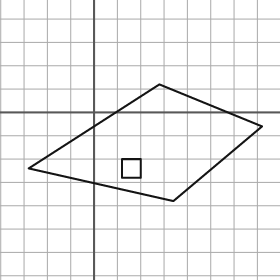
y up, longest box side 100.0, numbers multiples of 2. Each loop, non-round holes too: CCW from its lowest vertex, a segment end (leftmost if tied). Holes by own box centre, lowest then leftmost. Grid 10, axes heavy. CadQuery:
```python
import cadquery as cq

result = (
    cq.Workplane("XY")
    .moveTo(34.0, -38.0)
    .lineTo(72.0, -6.0)
    .lineTo(28.0, 12.0)
    .lineTo(-28.0, -24.0)
    .close()
    .moveTo(12.0, -28.0)
    .lineTo(20.0, -28.0)
    .lineTo(20.0, -20.0)
    .lineTo(12.0, -20.0)
    .close()
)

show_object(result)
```